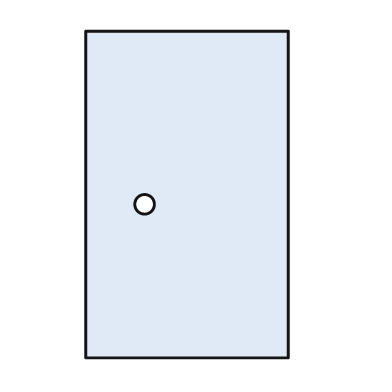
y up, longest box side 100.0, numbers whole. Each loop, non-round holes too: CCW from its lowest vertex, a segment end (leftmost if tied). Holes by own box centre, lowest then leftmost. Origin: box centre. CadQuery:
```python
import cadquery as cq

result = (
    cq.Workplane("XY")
    .moveTo(-31.0, -50.0)
    .lineTo(31.0, -50.0)
    .lineTo(31.0, 50.0)
    .lineTo(-31.0, 50.0)
    .close()
    .moveTo(-13.0, -3.0)
    .circle(3.0)
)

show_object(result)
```